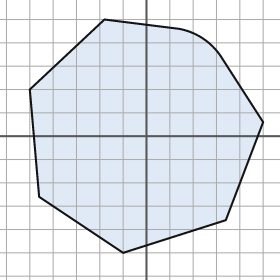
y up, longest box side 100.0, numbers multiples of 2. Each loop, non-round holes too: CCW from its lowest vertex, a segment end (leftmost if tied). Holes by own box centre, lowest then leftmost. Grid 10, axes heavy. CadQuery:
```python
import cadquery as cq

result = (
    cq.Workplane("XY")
    .moveTo(-10.0, -50.0)
    .lineTo(34.0, -36.0)
    .lineTo(50.0, 6.0)
    .lineTo(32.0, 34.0)
    .threePointArc((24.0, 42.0), (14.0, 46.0))
    .lineTo(-18.0, 50.0)
    .lineTo(-50.0, 20.0)
    .lineTo(-46.0, -26.0)
    .close()
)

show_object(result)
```